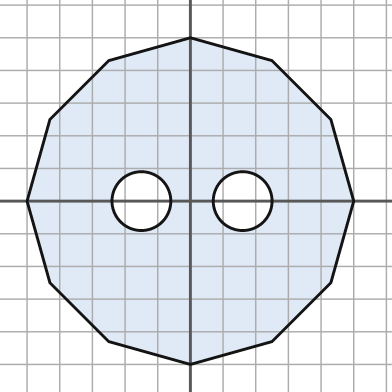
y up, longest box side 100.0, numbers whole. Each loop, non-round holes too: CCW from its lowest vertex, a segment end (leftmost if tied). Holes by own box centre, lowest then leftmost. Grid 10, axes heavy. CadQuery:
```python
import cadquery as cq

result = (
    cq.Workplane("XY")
    .moveTo(0.0, -50.0)
    .lineTo(25.0, -43.0)
    .lineTo(43.0, -25.0)
    .lineTo(50.0, 0.0)
    .lineTo(43.0, 25.0)
    .lineTo(25.0, 43.0)
    .lineTo(0.0, 50.0)
    .lineTo(-25.0, 43.0)
    .lineTo(-43.0, 25.0)
    .lineTo(-50.0, 0.0)
    .lineTo(-43.0, -25.0)
    .lineTo(-25.0, -43.0)
    .close()
    .moveTo(-15.0, 0.0)
    .circle(9.0)
    .moveTo(16.0, 0.0)
    .circle(9.0)
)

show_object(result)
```